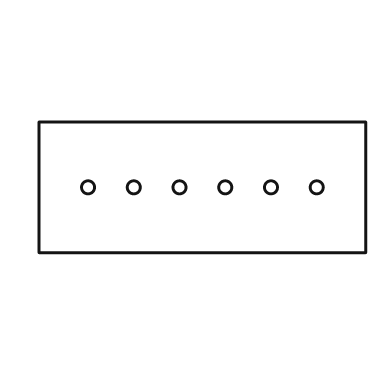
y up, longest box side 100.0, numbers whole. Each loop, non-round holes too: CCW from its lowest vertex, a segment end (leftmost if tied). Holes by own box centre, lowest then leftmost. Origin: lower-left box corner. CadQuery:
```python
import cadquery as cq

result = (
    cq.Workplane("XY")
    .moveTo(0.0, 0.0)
    .lineTo(100.0, 0.0)
    .lineTo(100.0, 40.0)
    .lineTo(0.0, 40.0)
    .close()
    .moveTo(15.0, 20.0)
    .circle(2.0)
    .moveTo(29.0, 20.0)
    .circle(2.0)
    .moveTo(43.0, 20.0)
    .circle(2.0)
    .moveTo(57.0, 20.0)
    .circle(2.0)
    .moveTo(71.0, 20.0)
    .circle(2.0)
    .moveTo(85.0, 20.0)
    .circle(2.0)
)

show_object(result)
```